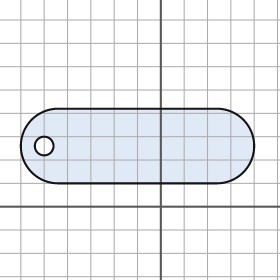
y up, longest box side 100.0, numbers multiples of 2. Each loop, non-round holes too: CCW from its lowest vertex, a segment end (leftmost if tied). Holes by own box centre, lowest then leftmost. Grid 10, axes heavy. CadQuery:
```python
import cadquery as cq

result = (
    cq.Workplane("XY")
    .moveTo(-44.0, 10.0)
    .lineTo(24.0, 10.0)
    .threePointArc((40.0, 26.0), (24.0, 42.0))
    .lineTo(-44.0, 42.0)
    .threePointArc((-60.0, 26.0), (-44.0, 10.0))
    .close()
    .moveTo(-50.0, 26.0)
    .circle(4.0)
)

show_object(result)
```